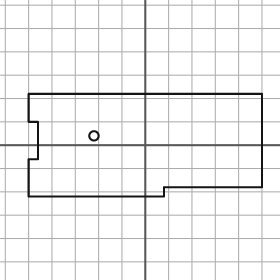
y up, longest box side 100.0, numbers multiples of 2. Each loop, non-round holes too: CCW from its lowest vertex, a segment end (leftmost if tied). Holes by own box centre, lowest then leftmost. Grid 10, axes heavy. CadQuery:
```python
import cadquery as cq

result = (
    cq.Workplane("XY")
    .moveTo(-50.0, -22.0)
    .lineTo(8.0, -22.0)
    .lineTo(8.0, -18.0)
    .lineTo(50.0, -18.0)
    .lineTo(50.0, 22.0)
    .lineTo(-50.0, 22.0)
    .lineTo(-50.0, 10.0)
    .lineTo(-46.0, 10.0)
    .lineTo(-46.0, -6.0)
    .lineTo(-50.0, -6.0)
    .close()
    .moveTo(-22.0, 4.0)
    .circle(2.0)
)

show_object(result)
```